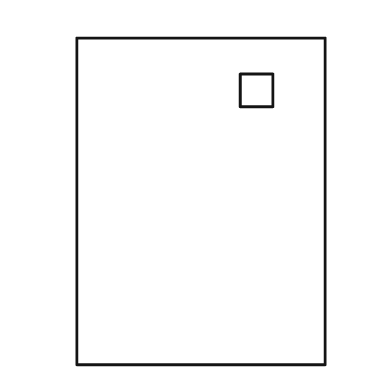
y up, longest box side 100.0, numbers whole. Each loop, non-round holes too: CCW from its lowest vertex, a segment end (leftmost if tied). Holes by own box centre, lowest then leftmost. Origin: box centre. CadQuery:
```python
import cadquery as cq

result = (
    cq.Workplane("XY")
    .moveTo(-38.0, -50.0)
    .lineTo(38.0, -50.0)
    .lineTo(38.0, 50.0)
    .lineTo(-38.0, 50.0)
    .close()
    .moveTo(12.0, 29.0)
    .lineTo(22.0, 29.0)
    .lineTo(22.0, 39.0)
    .lineTo(12.0, 39.0)
    .close()
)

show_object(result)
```